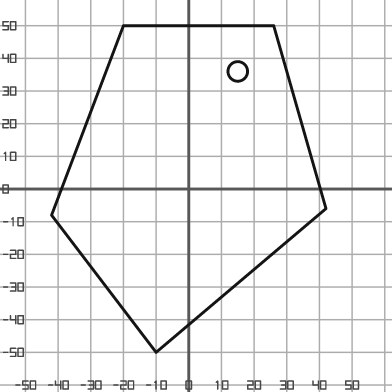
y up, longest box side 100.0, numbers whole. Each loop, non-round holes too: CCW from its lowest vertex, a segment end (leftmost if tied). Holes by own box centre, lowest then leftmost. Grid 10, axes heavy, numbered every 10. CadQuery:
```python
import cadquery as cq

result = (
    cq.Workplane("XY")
    .moveTo(-10.0, -50.0)
    .lineTo(42.0, -6.0)
    .lineTo(26.0, 50.0)
    .lineTo(-20.0, 50.0)
    .lineTo(-42.0, -8.0)
    .close()
    .moveTo(15.0, 36.0)
    .circle(3.0)
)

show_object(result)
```